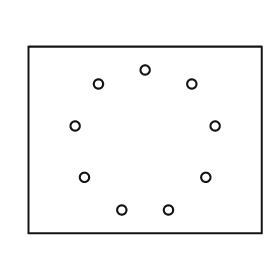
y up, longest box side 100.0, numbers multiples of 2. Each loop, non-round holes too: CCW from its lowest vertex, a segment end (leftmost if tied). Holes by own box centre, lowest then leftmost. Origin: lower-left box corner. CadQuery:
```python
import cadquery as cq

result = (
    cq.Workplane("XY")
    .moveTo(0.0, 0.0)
    .lineTo(100.0, 0.0)
    .lineTo(100.0, 80.0)
    .lineTo(0.0, 80.0)
    .close()
    .moveTo(40.0, 10.0)
    .circle(2.0)
    .moveTo(60.0, 10.0)
    .circle(2.0)
    .moveTo(24.0, 24.0)
    .circle(2.0)
    .moveTo(76.0, 24.0)
    .circle(2.0)
    .moveTo(20.0, 46.0)
    .circle(2.0)
    .moveTo(80.0, 46.0)
    .circle(2.0)
    .moveTo(30.0, 64.0)
    .circle(2.0)
    .moveTo(70.0, 64.0)
    .circle(2.0)
    .moveTo(50.0, 70.0)
    .circle(2.0)
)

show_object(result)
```